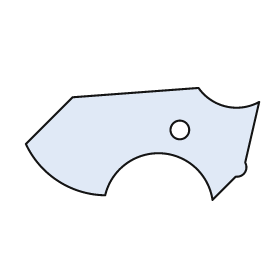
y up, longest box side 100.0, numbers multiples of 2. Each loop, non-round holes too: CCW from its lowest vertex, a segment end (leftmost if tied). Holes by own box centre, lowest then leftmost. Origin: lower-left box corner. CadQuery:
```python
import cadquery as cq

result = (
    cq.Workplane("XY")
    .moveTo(80.0, 0.0)
    .lineTo(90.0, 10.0)
    .threePointArc((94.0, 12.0), (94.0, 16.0))
    .lineTo(100.0, 42.0)
    .threePointArc((86.0, 40.0), (74.0, 48.0))
    .lineTo(20.0, 44.0)
    .lineTo(0.0, 24.0)
    .threePointArc((14.0, 8.0), (34.0, 2.0))
    .threePointArc((58.0, 20.0), (80.0, 0.0))
    .close()
    .moveTo(66.0, 30.0)
    .circle(4.0)
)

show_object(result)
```